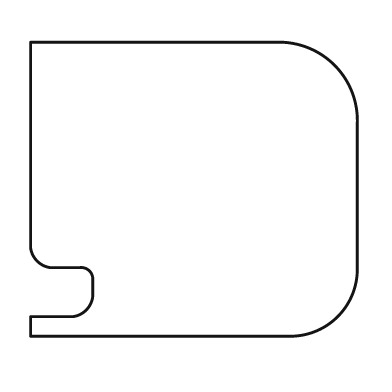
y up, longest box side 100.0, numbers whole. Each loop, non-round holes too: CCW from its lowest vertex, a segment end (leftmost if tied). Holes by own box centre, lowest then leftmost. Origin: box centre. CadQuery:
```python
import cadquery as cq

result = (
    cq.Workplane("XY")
    .moveTo(-50.0, -45.0)
    .lineTo(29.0, -45.0)
    .threePointArc((44.0, -39.0), (50.0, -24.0))
    .lineTo(50.0, 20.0)
    .threePointArc((43.0, 38.0), (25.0, 45.0))
    .lineTo(-50.0, 45.0)
    .lineTo(-50.0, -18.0)
    .threePointArc((-48.0, -22.0), (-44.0, -24.0))
    .lineTo(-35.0, -24.0)
    .threePointArc((-32.0, -25.0), (-31.0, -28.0))
    .lineTo(-31.0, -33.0)
    .threePointArc((-33.0, -37.0), (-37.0, -39.0))
    .lineTo(-50.0, -39.0)
    .close()
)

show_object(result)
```